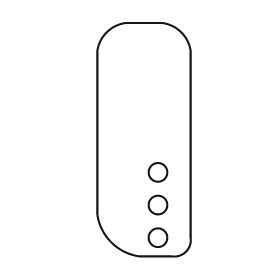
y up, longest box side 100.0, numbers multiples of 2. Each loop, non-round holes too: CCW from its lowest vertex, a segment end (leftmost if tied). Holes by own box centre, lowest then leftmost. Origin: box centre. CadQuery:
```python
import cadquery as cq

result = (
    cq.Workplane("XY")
    .moveTo(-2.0, -50.0)
    .lineTo(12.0, -50.0)
    .threePointArc((18.0, -48.0), (20.0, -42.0))
    .lineTo(20.0, 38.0)
    .threePointArc((16.0, 46.0), (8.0, 50.0))
    .lineTo(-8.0, 50.0)
    .threePointArc((-16.0, 46.0), (-20.0, 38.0))
    .lineTo(-20.0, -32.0)
    .threePointArc((-14.0, -44.0), (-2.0, -50.0))
    .close()
    .moveTo(6.0, -42.0)
    .circle(4.0)
    .moveTo(6.0, -28.0)
    .circle(4.0)
    .moveTo(6.0, -14.0)
    .circle(4.0)
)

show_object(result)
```